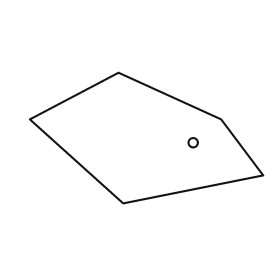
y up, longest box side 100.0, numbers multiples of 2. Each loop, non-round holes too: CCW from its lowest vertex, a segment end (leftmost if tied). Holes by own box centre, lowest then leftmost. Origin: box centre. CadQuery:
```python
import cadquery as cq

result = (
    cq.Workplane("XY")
    .moveTo(-10.0, -28.0)
    .lineTo(50.0, -16.0)
    .lineTo(32.0, 8.0)
    .lineTo(-12.0, 28.0)
    .lineTo(-50.0, 8.0)
    .close()
    .moveTo(20.0, -2.0)
    .circle(2.0)
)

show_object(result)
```